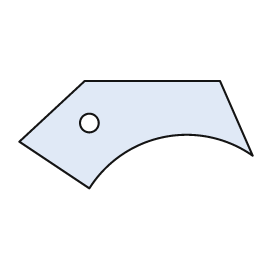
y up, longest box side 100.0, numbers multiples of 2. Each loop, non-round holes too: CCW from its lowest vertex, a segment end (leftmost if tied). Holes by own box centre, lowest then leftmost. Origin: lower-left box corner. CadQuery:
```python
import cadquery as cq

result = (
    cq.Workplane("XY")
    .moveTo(30.0, 0.0)
    .threePointArc((62.0, 22.0), (100.0, 14.0))
    .lineTo(86.0, 46.0)
    .lineTo(28.0, 46.0)
    .lineTo(0.0, 20.0)
    .close()
    .moveTo(30.0, 28.0)
    .circle(4.0)
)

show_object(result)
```